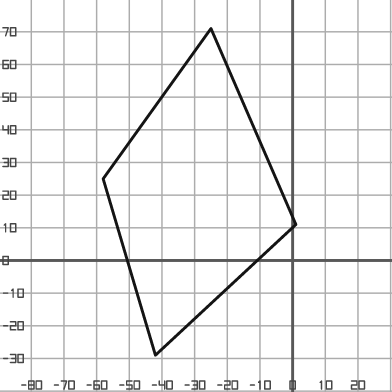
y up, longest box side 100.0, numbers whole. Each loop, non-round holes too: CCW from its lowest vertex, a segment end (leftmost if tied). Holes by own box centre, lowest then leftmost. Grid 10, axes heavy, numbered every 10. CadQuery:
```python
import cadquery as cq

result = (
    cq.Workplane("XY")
    .moveTo(-42.0, -29.0)
    .lineTo(1.0, 11.0)
    .lineTo(-25.0, 71.0)
    .lineTo(-58.0, 25.0)
    .close()
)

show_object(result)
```